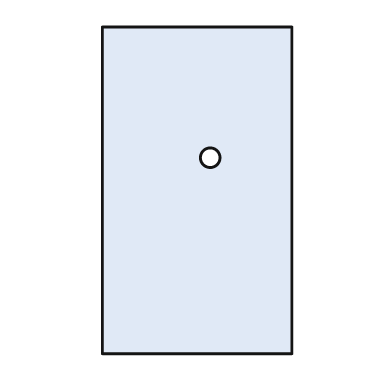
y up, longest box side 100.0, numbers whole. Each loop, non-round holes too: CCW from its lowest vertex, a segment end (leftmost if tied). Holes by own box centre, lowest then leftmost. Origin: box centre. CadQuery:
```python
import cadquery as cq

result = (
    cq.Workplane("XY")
    .moveTo(-29.0, -50.0)
    .lineTo(29.0, -50.0)
    .lineTo(29.0, 50.0)
    .lineTo(-29.0, 50.0)
    .close()
    .moveTo(4.0, 10.0)
    .circle(3.0)
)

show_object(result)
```